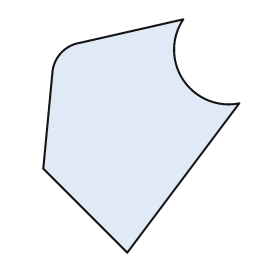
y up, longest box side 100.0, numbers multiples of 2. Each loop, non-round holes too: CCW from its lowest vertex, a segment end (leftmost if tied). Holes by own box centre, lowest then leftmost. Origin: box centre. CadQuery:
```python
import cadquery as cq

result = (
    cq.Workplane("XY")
    .moveTo(-6.0, -50.0)
    .lineTo(42.0, 14.0)
    .threePointArc((18.0, 24.0), (18.0, 50.0))
    .lineTo(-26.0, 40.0)
    .threePointArc((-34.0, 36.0), (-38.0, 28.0))
    .lineTo(-42.0, -14.0)
    .close()
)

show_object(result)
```